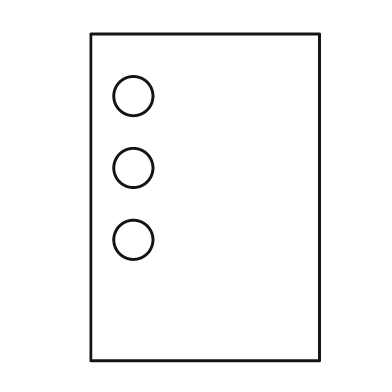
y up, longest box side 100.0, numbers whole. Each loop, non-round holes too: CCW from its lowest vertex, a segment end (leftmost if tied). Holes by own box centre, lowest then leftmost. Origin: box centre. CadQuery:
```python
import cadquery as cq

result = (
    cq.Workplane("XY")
    .moveTo(-35.0, -50.0)
    .lineTo(35.0, -50.0)
    .lineTo(35.0, 50.0)
    .lineTo(-35.0, 50.0)
    .close()
    .moveTo(-22.0, -13.0)
    .circle(6.0)
    .moveTo(-22.0, 9.0)
    .circle(6.0)
    .moveTo(-22.0, 31.0)
    .circle(6.0)
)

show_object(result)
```